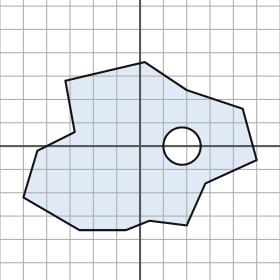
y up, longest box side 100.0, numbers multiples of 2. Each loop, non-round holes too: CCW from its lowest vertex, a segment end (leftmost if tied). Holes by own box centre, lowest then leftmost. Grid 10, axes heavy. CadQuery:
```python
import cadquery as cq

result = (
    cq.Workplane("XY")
    .moveTo(-26.0, -36.0)
    .lineTo(-6.0, -36.0)
    .lineTo(4.0, -32.0)
    .lineTo(20.0, -34.0)
    .lineTo(28.0, -16.0)
    .lineTo(50.0, -6.0)
    .lineTo(44.0, 16.0)
    .lineTo(20.0, 24.0)
    .lineTo(2.0, 36.0)
    .lineTo(-32.0, 28.0)
    .lineTo(-28.0, 6.0)
    .lineTo(-44.0, -2.0)
    .lineTo(-50.0, -22.0)
    .close()
    .moveTo(18.0, 0.0)
    .circle(8.0)
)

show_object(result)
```